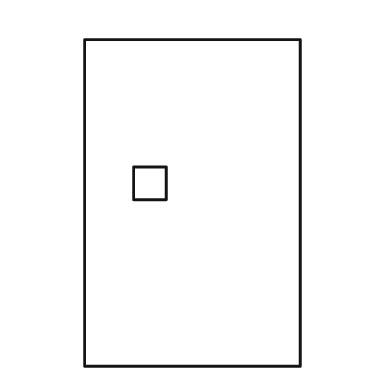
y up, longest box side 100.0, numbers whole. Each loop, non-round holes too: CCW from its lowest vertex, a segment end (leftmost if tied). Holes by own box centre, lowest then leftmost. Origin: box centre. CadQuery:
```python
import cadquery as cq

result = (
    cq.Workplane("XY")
    .moveTo(-33.0, -50.0)
    .lineTo(33.0, -50.0)
    .lineTo(33.0, 50.0)
    .lineTo(-33.0, 50.0)
    .close()
    .moveTo(-18.0, 1.0)
    .lineTo(-8.0, 1.0)
    .lineTo(-8.0, 11.0)
    .lineTo(-18.0, 11.0)
    .close()
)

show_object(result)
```